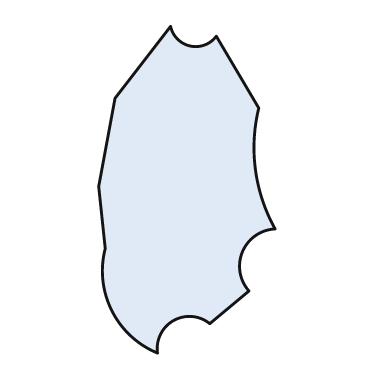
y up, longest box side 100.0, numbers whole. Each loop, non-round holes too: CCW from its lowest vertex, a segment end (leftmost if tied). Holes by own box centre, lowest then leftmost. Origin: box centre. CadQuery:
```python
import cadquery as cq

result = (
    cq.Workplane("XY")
    .moveTo(-9.0, -50.0)
    .threePointArc((-4.0, -40.0), (7.0, -41.0))
    .lineTo(19.0, -31.0)
    .threePointArc((17.0, -19.0), (27.0, -12.0))
    .threePointArc((21.0, 6.0), (22.0, 25.0))
    .lineTo(9.0, 47.0)
    .threePointArc((1.0, 44.0), (-5.0, 50.0))
    .lineTo(-22.0, 28.0)
    .lineTo(-27.0, 1.0)
    .lineTo(-25.0, -18.0)
    .threePointArc((-23.0, -37.0), (-9.0, -50.0))
    .close()
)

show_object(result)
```